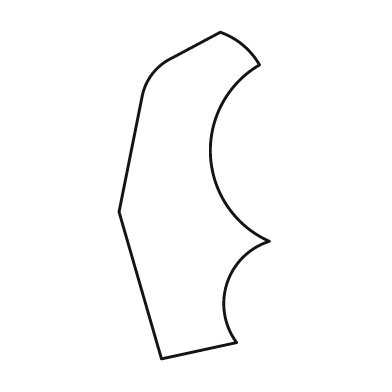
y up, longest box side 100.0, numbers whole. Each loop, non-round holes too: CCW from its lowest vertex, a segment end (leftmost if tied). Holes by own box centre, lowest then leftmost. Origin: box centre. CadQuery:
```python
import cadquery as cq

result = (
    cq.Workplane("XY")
    .moveTo(-10.0, -50.0)
    .lineTo(13.0, -45.0)
    .threePointArc((10.0, -27.0), (23.0, -14.0))
    .threePointArc((5.0, 12.0), (20.0, 40.0))
    .threePointArc((15.0, 46.0), (8.0, 50.0))
    .lineTo(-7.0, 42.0)
    .threePointArc((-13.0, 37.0), (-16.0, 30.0))
    .lineTo(-23.0, -5.0)
    .close()
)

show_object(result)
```